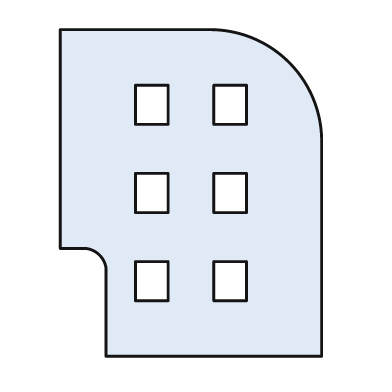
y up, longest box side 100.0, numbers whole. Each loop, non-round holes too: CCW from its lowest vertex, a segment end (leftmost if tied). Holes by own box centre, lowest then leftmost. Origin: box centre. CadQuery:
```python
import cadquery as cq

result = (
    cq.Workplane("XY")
    .moveTo(-26.0, -50.0)
    .lineTo(40.0, -50.0)
    .lineTo(40.0, 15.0)
    .threePointArc((30.0, 40.0), (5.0, 50.0))
    .lineTo(-40.0, 50.0)
    .lineTo(-40.0, -17.0)
    .lineTo(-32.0, -17.0)
    .threePointArc((-28.0, -19.0), (-26.0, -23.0))
    .close()
    .moveTo(-17.0, -33.0)
    .lineTo(-7.0, -33.0)
    .lineTo(-7.0, -21.0)
    .lineTo(-17.0, -21.0)
    .close()
    .moveTo(7.0, -33.0)
    .lineTo(17.0, -33.0)
    .lineTo(17.0, -21.0)
    .lineTo(7.0, -21.0)
    .close()
    .moveTo(-17.0, -6.0)
    .lineTo(-7.0, -6.0)
    .lineTo(-7.0, 6.0)
    .lineTo(-17.0, 6.0)
    .close()
    .moveTo(7.0, -6.0)
    .lineTo(17.0, -6.0)
    .lineTo(17.0, 6.0)
    .lineTo(7.0, 6.0)
    .close()
    .moveTo(-17.0, 21.0)
    .lineTo(-7.0, 21.0)
    .lineTo(-7.0, 33.0)
    .lineTo(-17.0, 33.0)
    .close()
    .moveTo(7.0, 21.0)
    .lineTo(17.0, 21.0)
    .lineTo(17.0, 33.0)
    .lineTo(7.0, 33.0)
    .close()
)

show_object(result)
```